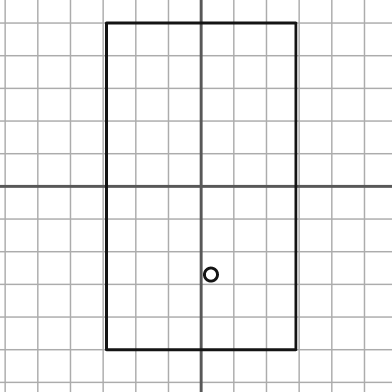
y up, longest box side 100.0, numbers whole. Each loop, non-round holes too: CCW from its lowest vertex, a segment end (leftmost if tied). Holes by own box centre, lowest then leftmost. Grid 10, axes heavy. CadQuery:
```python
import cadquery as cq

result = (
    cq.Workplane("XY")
    .moveTo(-29.0, -50.0)
    .lineTo(29.0, -50.0)
    .lineTo(29.0, 50.0)
    .lineTo(-29.0, 50.0)
    .close()
    .moveTo(3.0, -27.0)
    .circle(2.0)
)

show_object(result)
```